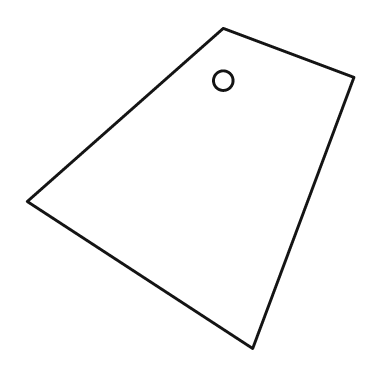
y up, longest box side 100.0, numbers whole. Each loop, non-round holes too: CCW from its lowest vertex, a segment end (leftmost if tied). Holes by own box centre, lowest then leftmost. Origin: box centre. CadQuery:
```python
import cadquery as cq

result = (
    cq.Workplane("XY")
    .moveTo(19.0, -49.0)
    .lineTo(50.0, 34.0)
    .lineTo(10.0, 49.0)
    .lineTo(-50.0, -4.0)
    .close()
    .moveTo(10.0, 33.0)
    .circle(3.0)
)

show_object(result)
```